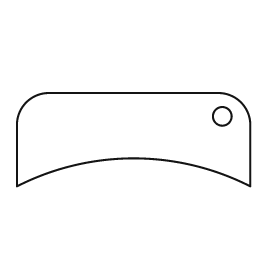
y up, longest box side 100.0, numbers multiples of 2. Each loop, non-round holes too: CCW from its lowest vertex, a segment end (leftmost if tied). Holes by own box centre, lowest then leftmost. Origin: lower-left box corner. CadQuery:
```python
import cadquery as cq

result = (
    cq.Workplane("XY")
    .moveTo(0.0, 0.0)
    .threePointArc((50.0, 12.0), (100.0, 0.0))
    .lineTo(100.0, 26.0)
    .threePointArc((96.0, 36.0), (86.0, 40.0))
    .lineTo(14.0, 40.0)
    .threePointArc((4.0, 36.0), (0.0, 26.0))
    .close()
    .moveTo(88.0, 30.0)
    .circle(4.0)
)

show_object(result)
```